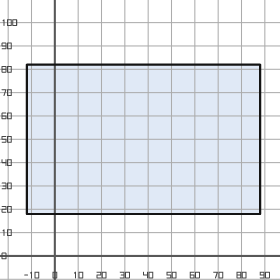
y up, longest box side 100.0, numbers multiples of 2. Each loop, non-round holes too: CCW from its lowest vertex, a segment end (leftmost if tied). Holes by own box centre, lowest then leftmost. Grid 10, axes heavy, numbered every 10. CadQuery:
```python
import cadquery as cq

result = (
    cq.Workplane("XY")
    .moveTo(-12.0, 18.0)
    .lineTo(88.0, 18.0)
    .lineTo(88.0, 82.0)
    .lineTo(-12.0, 82.0)
    .close()
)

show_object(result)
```